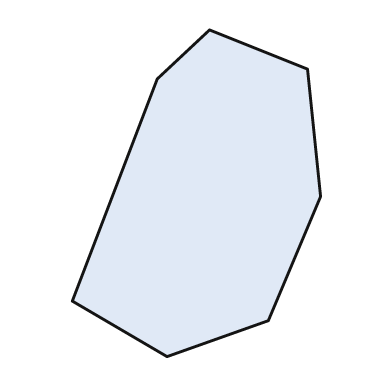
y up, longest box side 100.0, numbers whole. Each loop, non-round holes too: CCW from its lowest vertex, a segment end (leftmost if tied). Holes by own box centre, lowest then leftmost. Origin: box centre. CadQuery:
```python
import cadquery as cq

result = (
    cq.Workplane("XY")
    .moveTo(-9.0, -50.0)
    .lineTo(22.0, -39.0)
    .lineTo(38.0, -1.0)
    .lineTo(34.0, 38.0)
    .lineTo(4.0, 50.0)
    .lineTo(-12.0, 35.0)
    .lineTo(-38.0, -33.0)
    .close()
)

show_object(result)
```